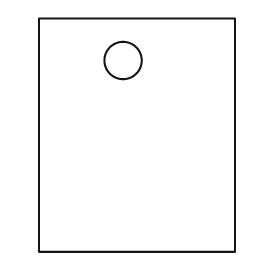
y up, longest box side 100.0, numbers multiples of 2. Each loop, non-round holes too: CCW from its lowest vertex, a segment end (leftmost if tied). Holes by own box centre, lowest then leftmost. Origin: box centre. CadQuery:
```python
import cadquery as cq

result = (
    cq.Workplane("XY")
    .moveTo(-42.0, -50.0)
    .lineTo(42.0, -50.0)
    .lineTo(42.0, 50.0)
    .lineTo(-42.0, 50.0)
    .close()
    .moveTo(-6.0, 32.0)
    .circle(8.0)
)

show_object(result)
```